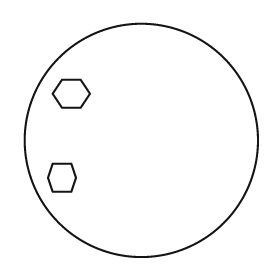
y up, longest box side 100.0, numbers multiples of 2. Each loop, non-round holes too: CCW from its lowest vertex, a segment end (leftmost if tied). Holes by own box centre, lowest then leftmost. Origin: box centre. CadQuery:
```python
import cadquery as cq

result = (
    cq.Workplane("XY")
    .moveTo(0.0, 0.0)
    .circle(50.0)
    .moveTo(-38.0, -22.0)
    .lineTo(-30.0, -22.0)
    .lineTo(-28.0, -16.0)
    .lineTo(-30.0, -10.0)
    .lineTo(-38.0, -10.0)
    .lineTo(-40.0, -16.0)
    .close()
    .moveTo(-34.0, 14.0)
    .lineTo(-26.0, 14.0)
    .lineTo(-22.0, 20.0)
    .lineTo(-26.0, 26.0)
    .lineTo(-34.0, 26.0)
    .lineTo(-38.0, 20.0)
    .close()
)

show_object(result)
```